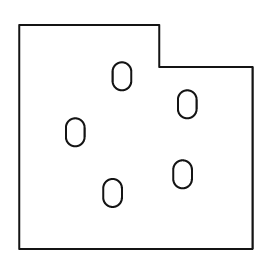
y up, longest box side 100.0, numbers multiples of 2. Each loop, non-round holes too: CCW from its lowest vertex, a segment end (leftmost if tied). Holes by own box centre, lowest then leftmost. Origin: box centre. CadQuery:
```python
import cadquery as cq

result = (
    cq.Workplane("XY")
    .moveTo(-50.0, -48.0)
    .lineTo(50.0, -48.0)
    .lineTo(50.0, 30.0)
    .lineTo(10.0, 30.0)
    .lineTo(10.0, 48.0)
    .lineTo(-50.0, 48.0)
    .close()
    .moveTo(-14.0, -26.0)
    .threePointArc((-10.0, -30.0), (-6.0, -26.0))
    .lineTo(-6.0, -22.0)
    .threePointArc((-10.0, -18.0), (-14.0, -22.0))
    .close()
    .moveTo(16.0, -18.0)
    .threePointArc((20.0, -22.0), (24.0, -18.0))
    .lineTo(24.0, -14.0)
    .threePointArc((20.0, -10.0), (16.0, -14.0))
    .close()
    .moveTo(-30.0, 0.0)
    .threePointArc((-26.0, -4.0), (-22.0, 0.0))
    .lineTo(-22.0, 4.0)
    .threePointArc((-26.0, 8.0), (-30.0, 4.0))
    .close()
    .moveTo(18.0, 12.0)
    .threePointArc((22.0, 8.0), (26.0, 12.0))
    .lineTo(26.0, 16.0)
    .threePointArc((22.0, 20.0), (18.0, 16.0))
    .close()
    .moveTo(-10.0, 24.0)
    .threePointArc((-6.0, 20.0), (-2.0, 24.0))
    .lineTo(-2.0, 28.0)
    .threePointArc((-6.0, 32.0), (-10.0, 28.0))
    .close()
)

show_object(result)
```